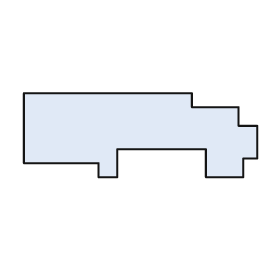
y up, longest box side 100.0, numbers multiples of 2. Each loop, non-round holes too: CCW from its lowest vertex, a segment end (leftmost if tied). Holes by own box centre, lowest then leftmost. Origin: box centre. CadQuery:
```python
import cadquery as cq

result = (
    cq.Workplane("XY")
    .moveTo(-18.0, -18.0)
    .lineTo(-10.0, -18.0)
    .lineTo(-10.0, -6.0)
    .lineTo(28.0, -6.0)
    .lineTo(28.0, -18.0)
    .lineTo(44.0, -18.0)
    .lineTo(44.0, -10.0)
    .lineTo(50.0, -10.0)
    .lineTo(50.0, 4.0)
    .lineTo(42.0, 4.0)
    .lineTo(42.0, 12.0)
    .lineTo(22.0, 12.0)
    .lineTo(22.0, 18.0)
    .lineTo(-50.0, 18.0)
    .lineTo(-50.0, -12.0)
    .lineTo(-18.0, -12.0)
    .close()
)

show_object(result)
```